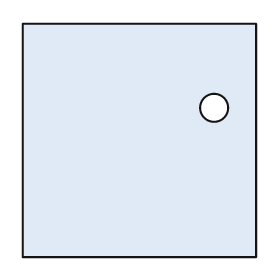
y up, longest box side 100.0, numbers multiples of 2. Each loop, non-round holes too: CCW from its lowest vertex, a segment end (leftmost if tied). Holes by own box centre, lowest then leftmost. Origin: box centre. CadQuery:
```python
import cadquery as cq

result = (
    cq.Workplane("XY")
    .moveTo(-50.0, -50.0)
    .lineTo(50.0, -50.0)
    .lineTo(50.0, 50.0)
    .lineTo(-50.0, 50.0)
    .close()
    .moveTo(32.0, 14.0)
    .circle(6.0)
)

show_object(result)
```